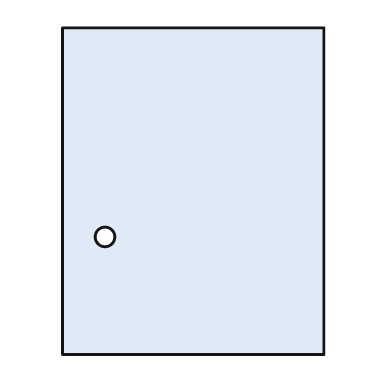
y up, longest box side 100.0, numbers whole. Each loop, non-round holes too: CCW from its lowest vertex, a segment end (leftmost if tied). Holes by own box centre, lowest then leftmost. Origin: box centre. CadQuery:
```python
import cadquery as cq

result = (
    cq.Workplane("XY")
    .moveTo(-40.0, -50.0)
    .lineTo(40.0, -50.0)
    .lineTo(40.0, 50.0)
    .lineTo(-40.0, 50.0)
    .close()
    .moveTo(-27.0, -14.0)
    .circle(3.0)
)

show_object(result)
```